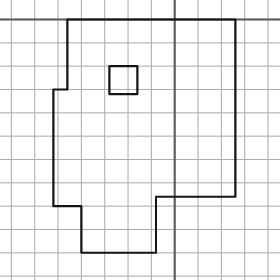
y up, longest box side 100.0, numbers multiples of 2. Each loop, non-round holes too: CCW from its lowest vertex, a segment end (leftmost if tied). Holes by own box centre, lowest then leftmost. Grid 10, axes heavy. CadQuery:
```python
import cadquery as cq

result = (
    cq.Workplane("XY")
    .moveTo(-40.0, -100.0)
    .lineTo(-8.0, -100.0)
    .lineTo(-8.0, -76.0)
    .lineTo(26.0, -76.0)
    .lineTo(26.0, 0.0)
    .lineTo(-46.0, 0.0)
    .lineTo(-46.0, -30.0)
    .lineTo(-52.0, -30.0)
    .lineTo(-52.0, -80.0)
    .lineTo(-40.0, -80.0)
    .close()
    .moveTo(-28.0, -32.0)
    .lineTo(-16.0, -32.0)
    .lineTo(-16.0, -20.0)
    .lineTo(-28.0, -20.0)
    .close()
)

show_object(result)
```